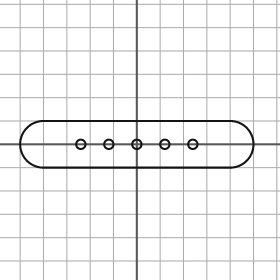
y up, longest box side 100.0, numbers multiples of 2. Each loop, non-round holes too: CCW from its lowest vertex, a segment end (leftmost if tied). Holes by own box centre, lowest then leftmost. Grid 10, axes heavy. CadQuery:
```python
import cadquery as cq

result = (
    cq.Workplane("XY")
    .moveTo(-40.0, -10.0)
    .lineTo(40.0, -10.0)
    .threePointArc((50.0, 0.0), (40.0, 10.0))
    .lineTo(-40.0, 10.0)
    .threePointArc((-50.0, 0.0), (-40.0, -10.0))
    .close()
    .moveTo(-24.0, 0.0)
    .circle(2.0)
    .moveTo(-12.0, 0.0)
    .circle(2.0)
    .moveTo(0.0, 0.0)
    .circle(2.0)
    .moveTo(12.0, 0.0)
    .circle(2.0)
    .moveTo(24.0, 0.0)
    .circle(2.0)
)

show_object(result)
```